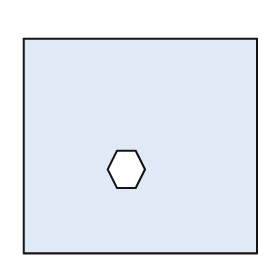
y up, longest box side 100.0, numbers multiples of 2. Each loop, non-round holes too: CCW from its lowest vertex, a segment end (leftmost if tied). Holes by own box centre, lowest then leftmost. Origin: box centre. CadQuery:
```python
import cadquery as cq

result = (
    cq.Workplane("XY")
    .moveTo(-50.0, -46.0)
    .lineTo(50.0, -46.0)
    .lineTo(50.0, 46.0)
    .lineTo(-50.0, 46.0)
    .close()
    .moveTo(-10.0, -18.0)
    .lineTo(-2.0, -18.0)
    .lineTo(2.0, -10.0)
    .lineTo(-2.0, -2.0)
    .lineTo(-10.0, -2.0)
    .lineTo(-14.0, -10.0)
    .close()
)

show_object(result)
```